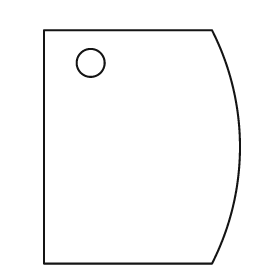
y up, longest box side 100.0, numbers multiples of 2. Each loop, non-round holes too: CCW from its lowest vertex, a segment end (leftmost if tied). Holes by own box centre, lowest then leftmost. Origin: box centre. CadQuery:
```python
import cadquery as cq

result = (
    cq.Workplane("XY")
    .moveTo(-42.0, -50.0)
    .lineTo(30.0, -50.0)
    .threePointArc((42.0, 0.0), (30.0, 50.0))
    .lineTo(-42.0, 50.0)
    .close()
    .moveTo(-22.0, 36.0)
    .circle(6.0)
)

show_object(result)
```